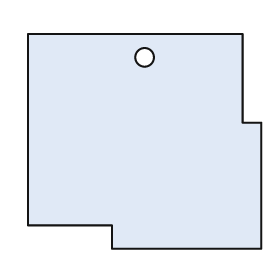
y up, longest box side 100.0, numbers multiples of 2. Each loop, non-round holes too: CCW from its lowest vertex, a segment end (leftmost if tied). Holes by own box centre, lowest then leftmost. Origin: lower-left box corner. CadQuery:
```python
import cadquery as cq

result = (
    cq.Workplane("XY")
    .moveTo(36.0, 0.0)
    .lineTo(100.0, 0.0)
    .lineTo(100.0, 54.0)
    .lineTo(92.0, 54.0)
    .lineTo(92.0, 92.0)
    .lineTo(0.0, 92.0)
    .lineTo(0.0, 10.0)
    .lineTo(36.0, 10.0)
    .close()
    .moveTo(50.0, 82.0)
    .circle(4.0)
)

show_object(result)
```